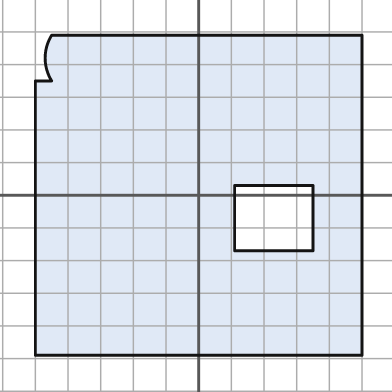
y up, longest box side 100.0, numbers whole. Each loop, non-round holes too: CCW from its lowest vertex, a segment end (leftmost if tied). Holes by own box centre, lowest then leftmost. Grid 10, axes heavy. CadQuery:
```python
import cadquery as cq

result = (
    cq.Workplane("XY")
    .moveTo(-50.0, -49.0)
    .lineTo(50.0, -49.0)
    .lineTo(50.0, 49.0)
    .lineTo(-45.0, 49.0)
    .threePointArc((-47.0, 42.0), (-45.0, 35.0))
    .lineTo(-50.0, 35.0)
    .close()
    .moveTo(11.0, -17.0)
    .lineTo(35.0, -17.0)
    .lineTo(35.0, 3.0)
    .lineTo(11.0, 3.0)
    .close()
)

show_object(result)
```